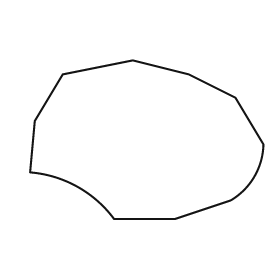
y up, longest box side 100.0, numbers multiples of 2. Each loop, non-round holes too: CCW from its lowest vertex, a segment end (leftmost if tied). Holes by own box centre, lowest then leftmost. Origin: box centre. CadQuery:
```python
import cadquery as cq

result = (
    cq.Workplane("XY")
    .moveTo(-14.0, -34.0)
    .lineTo(12.0, -34.0)
    .lineTo(36.0, -26.0)
    .threePointArc((46.0, -16.0), (50.0, -2.0))
    .lineTo(38.0, 18.0)
    .lineTo(18.0, 28.0)
    .lineTo(-6.0, 34.0)
    .lineTo(-36.0, 28.0)
    .lineTo(-48.0, 8.0)
    .lineTo(-50.0, -14.0)
    .threePointArc((-30.0, -20.0), (-14.0, -34.0))
    .close()
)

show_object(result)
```